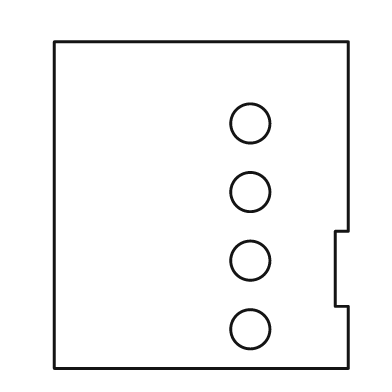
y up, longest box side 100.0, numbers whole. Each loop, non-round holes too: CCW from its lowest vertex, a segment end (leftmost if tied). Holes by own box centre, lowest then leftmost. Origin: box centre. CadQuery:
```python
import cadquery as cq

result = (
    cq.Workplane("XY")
    .moveTo(-45.0, -50.0)
    .lineTo(45.0, -50.0)
    .lineTo(45.0, -31.0)
    .lineTo(41.0, -31.0)
    .lineTo(41.0, -8.0)
    .lineTo(45.0, -8.0)
    .lineTo(45.0, 50.0)
    .lineTo(-45.0, 50.0)
    .close()
    .moveTo(15.0, -38.0)
    .circle(6.0)
    .moveTo(15.0, -17.0)
    .circle(6.0)
    .moveTo(15.0, 4.0)
    .circle(6.0)
    .moveTo(15.0, 25.0)
    .circle(6.0)
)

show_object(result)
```